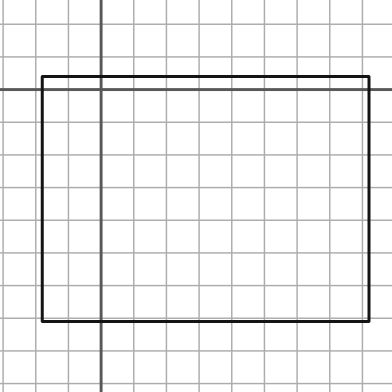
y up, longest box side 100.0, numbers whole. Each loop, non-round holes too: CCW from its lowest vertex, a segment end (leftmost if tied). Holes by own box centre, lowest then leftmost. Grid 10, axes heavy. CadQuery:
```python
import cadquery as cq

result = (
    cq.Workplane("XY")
    .moveTo(-18.0, -71.0)
    .lineTo(82.0, -71.0)
    .lineTo(82.0, 4.0)
    .lineTo(-18.0, 4.0)
    .close()
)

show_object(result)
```